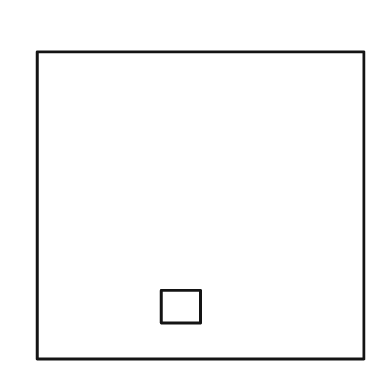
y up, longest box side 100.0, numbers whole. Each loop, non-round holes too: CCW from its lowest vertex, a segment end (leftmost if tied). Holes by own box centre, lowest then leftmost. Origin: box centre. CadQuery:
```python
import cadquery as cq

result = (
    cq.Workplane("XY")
    .moveTo(-50.0, -47.0)
    .lineTo(50.0, -47.0)
    .lineTo(50.0, 47.0)
    .lineTo(-50.0, 47.0)
    .close()
    .moveTo(-12.0, -36.0)
    .lineTo(0.0, -36.0)
    .lineTo(0.0, -26.0)
    .lineTo(-12.0, -26.0)
    .close()
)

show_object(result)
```